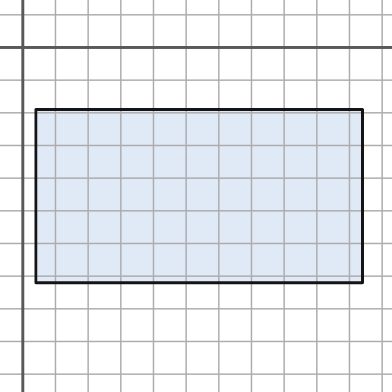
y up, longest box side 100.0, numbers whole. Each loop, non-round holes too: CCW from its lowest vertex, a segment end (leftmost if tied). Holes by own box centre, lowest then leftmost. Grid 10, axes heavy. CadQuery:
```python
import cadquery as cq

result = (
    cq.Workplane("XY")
    .moveTo(4.0, -72.0)
    .lineTo(104.0, -72.0)
    .lineTo(104.0, -19.0)
    .lineTo(4.0, -19.0)
    .close()
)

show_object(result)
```